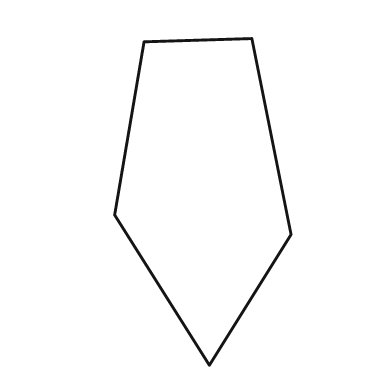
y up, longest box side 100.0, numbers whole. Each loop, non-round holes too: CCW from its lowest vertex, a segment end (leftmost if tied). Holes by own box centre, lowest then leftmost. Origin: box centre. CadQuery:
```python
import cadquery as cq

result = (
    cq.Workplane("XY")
    .moveTo(2.0, -50.0)
    .lineTo(27.0, -10.0)
    .lineTo(15.0, 50.0)
    .lineTo(-18.0, 49.0)
    .lineTo(-27.0, -4.0)
    .close()
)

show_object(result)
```